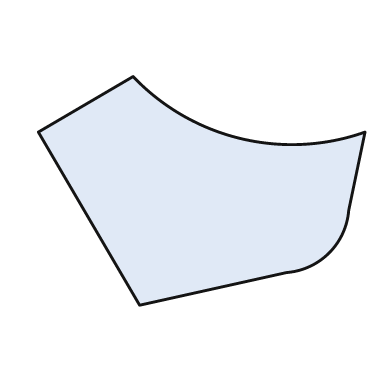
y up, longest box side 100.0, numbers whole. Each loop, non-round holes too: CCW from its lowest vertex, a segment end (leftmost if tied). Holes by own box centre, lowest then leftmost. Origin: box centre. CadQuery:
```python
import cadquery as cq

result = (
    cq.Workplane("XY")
    .moveTo(-19.0, -35.0)
    .lineTo(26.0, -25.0)
    .threePointArc((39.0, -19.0), (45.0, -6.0))
    .lineTo(50.0, 18.0)
    .threePointArc((12.0, 16.0), (-21.0, 35.0))
    .lineTo(-50.0, 18.0)
    .close()
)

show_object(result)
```